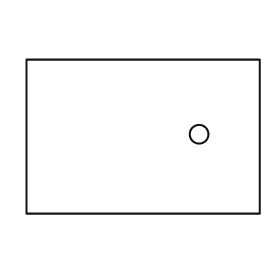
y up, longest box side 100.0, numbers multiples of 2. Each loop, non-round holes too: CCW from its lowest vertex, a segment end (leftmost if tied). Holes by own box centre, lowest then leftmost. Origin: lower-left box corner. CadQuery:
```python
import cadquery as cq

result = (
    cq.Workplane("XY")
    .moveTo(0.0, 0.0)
    .lineTo(100.0, 0.0)
    .lineTo(100.0, 66.0)
    .lineTo(0.0, 66.0)
    .close()
    .moveTo(74.0, 34.0)
    .circle(4.0)
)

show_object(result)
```